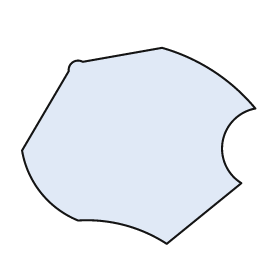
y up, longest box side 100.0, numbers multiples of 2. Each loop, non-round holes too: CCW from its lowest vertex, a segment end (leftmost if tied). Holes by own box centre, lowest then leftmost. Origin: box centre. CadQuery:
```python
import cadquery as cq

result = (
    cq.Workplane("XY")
    .moveTo(12.0, -42.0)
    .lineTo(44.0, -16.0)
    .threePointArc((36.0, 2.0), (50.0, 16.0))
    .threePointArc((32.0, 32.0), (10.0, 42.0))
    .lineTo(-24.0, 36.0)
    .threePointArc((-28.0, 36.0), (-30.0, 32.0))
    .lineTo(-50.0, -2.0)
    .threePointArc((-42.0, -20.0), (-26.0, -32.0))
    .threePointArc((-6.0, -34.0), (12.0, -42.0))
    .close()
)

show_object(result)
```